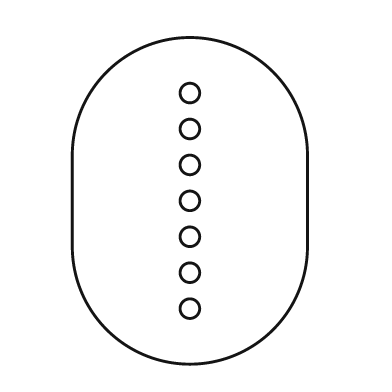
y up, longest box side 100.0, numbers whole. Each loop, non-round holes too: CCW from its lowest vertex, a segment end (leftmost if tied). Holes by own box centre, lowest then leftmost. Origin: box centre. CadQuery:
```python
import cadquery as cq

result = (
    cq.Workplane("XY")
    .moveTo(-36.0, -14.0)
    .threePointArc((0.0, -50.0), (36.0, -14.0))
    .lineTo(36.0, 14.0)
    .threePointArc((0.0, 50.0), (-36.0, 14.0))
    .close()
    .moveTo(0.0, -33.0)
    .circle(3.0)
    .moveTo(0.0, -22.0)
    .circle(3.0)
    .moveTo(0.0, -11.0)
    .circle(3.0)
    .moveTo(0.0, 0.0)
    .circle(3.0)
    .moveTo(0.0, 11.0)
    .circle(3.0)
    .moveTo(0.0, 22.0)
    .circle(3.0)
    .moveTo(0.0, 33.0)
    .circle(3.0)
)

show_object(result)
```